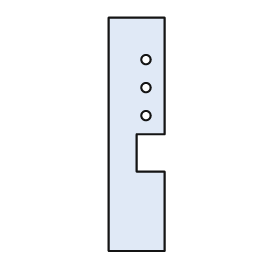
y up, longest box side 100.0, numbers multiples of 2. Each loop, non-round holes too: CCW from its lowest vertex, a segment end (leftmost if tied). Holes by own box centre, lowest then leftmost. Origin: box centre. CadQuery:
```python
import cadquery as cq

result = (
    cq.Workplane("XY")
    .moveTo(-12.0, -50.0)
    .lineTo(12.0, -50.0)
    .lineTo(12.0, -16.0)
    .lineTo(0.0, -16.0)
    .lineTo(0.0, 0.0)
    .lineTo(12.0, 0.0)
    .lineTo(12.0, 50.0)
    .lineTo(-12.0, 50.0)
    .close()
    .moveTo(4.0, 8.0)
    .circle(2.0)
    .moveTo(4.0, 20.0)
    .circle(2.0)
    .moveTo(4.0, 32.0)
    .circle(2.0)
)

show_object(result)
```